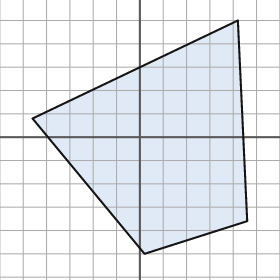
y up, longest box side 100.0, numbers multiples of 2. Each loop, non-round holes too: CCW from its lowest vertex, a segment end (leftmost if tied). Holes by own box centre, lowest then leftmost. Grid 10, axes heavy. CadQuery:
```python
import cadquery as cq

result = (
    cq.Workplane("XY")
    .moveTo(2.0, -50.0)
    .lineTo(46.0, -36.0)
    .lineTo(42.0, 50.0)
    .lineTo(-46.0, 8.0)
    .close()
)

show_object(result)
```